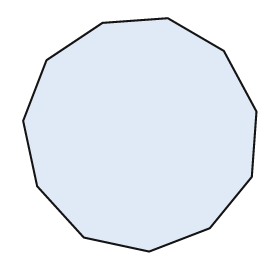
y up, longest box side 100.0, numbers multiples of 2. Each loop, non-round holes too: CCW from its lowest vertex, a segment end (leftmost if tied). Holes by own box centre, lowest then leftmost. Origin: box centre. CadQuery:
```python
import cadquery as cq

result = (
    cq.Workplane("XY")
    .moveTo(4.0, -50.0)
    .lineTo(30.0, -40.0)
    .lineTo(48.0, -18.0)
    .lineTo(50.0, 10.0)
    .lineTo(36.0, 36.0)
    .lineTo(12.0, 50.0)
    .lineTo(-16.0, 48.0)
    .lineTo(-40.0, 32.0)
    .lineTo(-50.0, 6.0)
    .lineTo(-44.0, -22.0)
    .lineTo(-24.0, -44.0)
    .close()
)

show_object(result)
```